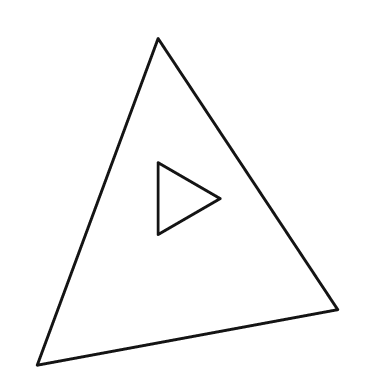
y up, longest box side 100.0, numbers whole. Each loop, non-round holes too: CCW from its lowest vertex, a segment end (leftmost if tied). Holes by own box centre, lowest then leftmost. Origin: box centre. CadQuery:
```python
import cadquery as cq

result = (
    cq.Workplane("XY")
    .moveTo(-46.0, -50.0)
    .lineTo(46.0, -33.0)
    .lineTo(-9.0, 50.0)
    .close()
    .moveTo(-9.0, -10.0)
    .lineTo(10.0, 1.0)
    .lineTo(-9.0, 12.0)
    .close()
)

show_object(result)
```